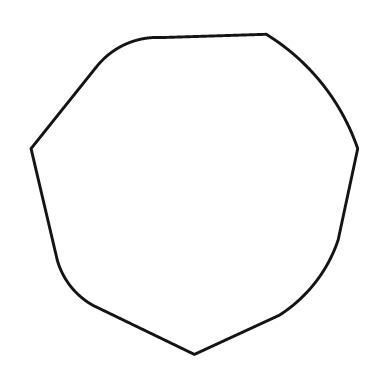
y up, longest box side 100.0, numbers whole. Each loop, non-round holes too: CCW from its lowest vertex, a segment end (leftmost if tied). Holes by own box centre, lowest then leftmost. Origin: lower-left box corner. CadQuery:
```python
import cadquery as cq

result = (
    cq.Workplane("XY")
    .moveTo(50.0, 0.0)
    .lineTo(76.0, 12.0)
    .threePointArc((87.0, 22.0), (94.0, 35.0))
    .lineTo(100.0, 63.0)
    .threePointArc((89.0, 83.0), (72.0, 98.0))
    .lineTo(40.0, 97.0)
    .threePointArc((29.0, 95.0), (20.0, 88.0))
    .lineTo(0.0, 63.0)
    .lineTo(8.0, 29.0)
    .threePointArc((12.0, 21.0), (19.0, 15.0))
    .close()
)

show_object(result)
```